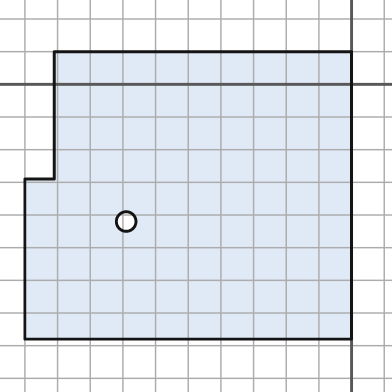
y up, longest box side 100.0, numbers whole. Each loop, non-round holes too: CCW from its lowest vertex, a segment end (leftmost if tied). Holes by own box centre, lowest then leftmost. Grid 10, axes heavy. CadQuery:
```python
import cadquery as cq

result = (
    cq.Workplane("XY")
    .moveTo(-100.0, -78.0)
    .lineTo(0.0, -78.0)
    .lineTo(0.0, 10.0)
    .lineTo(-91.0, 10.0)
    .lineTo(-91.0, -29.0)
    .lineTo(-100.0, -29.0)
    .close()
    .moveTo(-69.0, -42.0)
    .circle(3.0)
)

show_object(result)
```